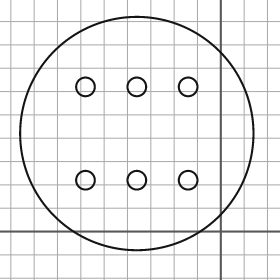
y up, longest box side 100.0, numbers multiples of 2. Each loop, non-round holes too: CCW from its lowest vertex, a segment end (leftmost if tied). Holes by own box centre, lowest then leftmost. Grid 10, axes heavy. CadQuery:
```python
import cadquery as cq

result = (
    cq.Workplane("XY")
    .moveTo(-36.0, 42.0)
    .circle(50.0)
    .moveTo(-58.0, 22.0)
    .circle(4.0)
    .moveTo(-36.0, 22.0)
    .circle(4.0)
    .moveTo(-14.0, 22.0)
    .circle(4.0)
    .moveTo(-58.0, 62.0)
    .circle(4.0)
    .moveTo(-36.0, 62.0)
    .circle(4.0)
    .moveTo(-14.0, 62.0)
    .circle(4.0)
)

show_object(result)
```